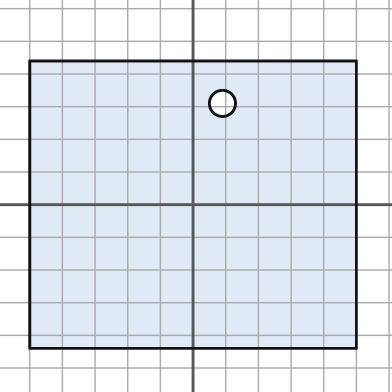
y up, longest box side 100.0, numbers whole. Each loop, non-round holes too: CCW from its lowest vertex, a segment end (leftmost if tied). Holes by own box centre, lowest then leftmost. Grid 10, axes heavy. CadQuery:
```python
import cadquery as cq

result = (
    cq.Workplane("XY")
    .moveTo(-50.0, -44.0)
    .lineTo(50.0, -44.0)
    .lineTo(50.0, 44.0)
    .lineTo(-50.0, 44.0)
    .close()
    .moveTo(9.0, 31.0)
    .circle(4.0)
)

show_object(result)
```